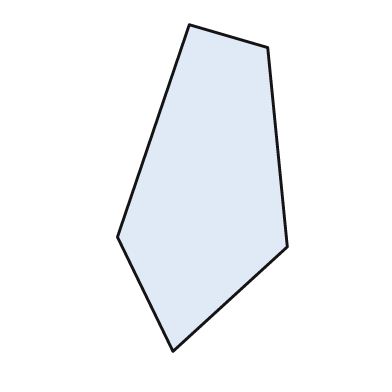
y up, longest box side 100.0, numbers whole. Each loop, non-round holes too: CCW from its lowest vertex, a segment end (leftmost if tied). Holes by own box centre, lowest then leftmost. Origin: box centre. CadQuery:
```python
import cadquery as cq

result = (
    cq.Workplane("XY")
    .moveTo(-9.0, -50.0)
    .lineTo(26.0, -18.0)
    .lineTo(20.0, 43.0)
    .lineTo(-4.0, 50.0)
    .lineTo(-26.0, -15.0)
    .close()
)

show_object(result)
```